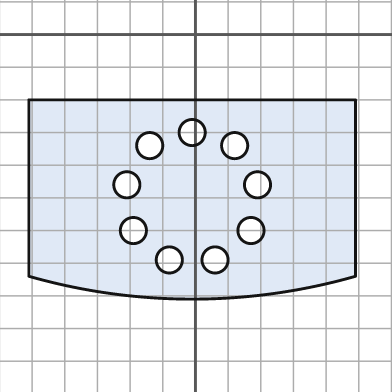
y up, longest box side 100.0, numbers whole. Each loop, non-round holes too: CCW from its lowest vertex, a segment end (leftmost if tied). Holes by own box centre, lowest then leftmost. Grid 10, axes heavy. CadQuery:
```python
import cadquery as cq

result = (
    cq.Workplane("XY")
    .moveTo(-51.0, -74.0)
    .threePointArc((-1.0, -81.0), (49.0, -74.0))
    .lineTo(49.0, -20.0)
    .lineTo(-51.0, -20.0)
    .close()
    .moveTo(-8.0, -69.0)
    .circle(4.0)
    .moveTo(6.0, -69.0)
    .circle(4.0)
    .moveTo(-19.0, -60.0)
    .circle(4.0)
    .moveTo(17.0, -60.0)
    .circle(4.0)
    .moveTo(-21.0, -46.0)
    .circle(4.0)
    .moveTo(19.0, -46.0)
    .circle(4.0)
    .moveTo(-14.0, -34.0)
    .circle(4.0)
    .moveTo(12.0, -34.0)
    .circle(4.0)
    .moveTo(-1.0, -30.0)
    .circle(4.0)
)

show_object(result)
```